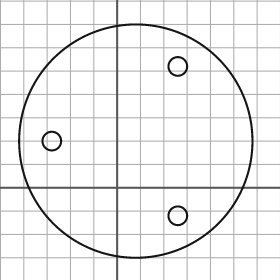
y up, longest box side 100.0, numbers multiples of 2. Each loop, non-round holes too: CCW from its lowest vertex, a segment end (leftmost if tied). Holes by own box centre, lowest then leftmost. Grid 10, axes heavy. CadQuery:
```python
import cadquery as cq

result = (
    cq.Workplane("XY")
    .moveTo(8.0, 20.0)
    .circle(50.0)
    .moveTo(26.0, -12.0)
    .circle(4.0)
    .moveTo(-28.0, 20.0)
    .circle(4.0)
    .moveTo(26.0, 52.0)
    .circle(4.0)
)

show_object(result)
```